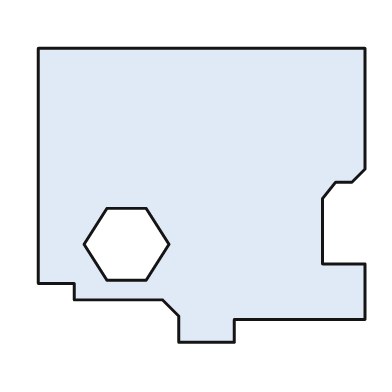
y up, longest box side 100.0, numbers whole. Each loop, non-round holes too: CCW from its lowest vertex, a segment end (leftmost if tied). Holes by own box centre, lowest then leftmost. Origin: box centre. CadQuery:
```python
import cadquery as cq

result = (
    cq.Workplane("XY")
    .moveTo(-7.0, -45.0)
    .lineTo(10.0, -45.0)
    .lineTo(10.0, -38.0)
    .lineTo(50.0, -38.0)
    .lineTo(50.0, -21.0)
    .lineTo(37.0, -21.0)
    .lineTo(37.0, -1.0)
    .lineTo(41.0, 4.0)
    .lineTo(46.0, 4.0)
    .lineTo(50.0, 8.0)
    .lineTo(50.0, 45.0)
    .lineTo(-50.0, 45.0)
    .lineTo(-50.0, -27.0)
    .lineTo(-39.0, -27.0)
    .lineTo(-39.0, -32.0)
    .lineTo(-12.0, -32.0)
    .lineTo(-7.0, -37.0)
    .close()
    .moveTo(-29.0, -26.0)
    .lineTo(-17.0, -26.0)
    .lineTo(-10.0, -15.0)
    .lineTo(-17.0, -4.0)
    .lineTo(-29.0, -4.0)
    .lineTo(-36.0, -15.0)
    .close()
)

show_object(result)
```